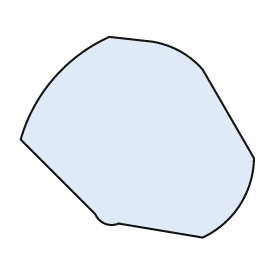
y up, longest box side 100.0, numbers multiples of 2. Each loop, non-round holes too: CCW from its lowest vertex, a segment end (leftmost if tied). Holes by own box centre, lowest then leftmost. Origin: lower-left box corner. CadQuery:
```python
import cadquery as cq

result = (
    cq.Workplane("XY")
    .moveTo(78.0, 0.0)
    .threePointArc((94.0, 14.0), (100.0, 34.0))
    .lineTo(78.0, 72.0)
    .threePointArc((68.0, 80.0), (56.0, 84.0))
    .lineTo(38.0, 86.0)
    .threePointArc((14.0, 68.0), (0.0, 42.0))
    .lineTo(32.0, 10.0)
    .threePointArc((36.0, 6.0), (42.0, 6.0))
    .close()
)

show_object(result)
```